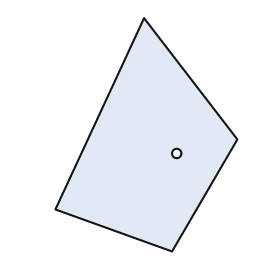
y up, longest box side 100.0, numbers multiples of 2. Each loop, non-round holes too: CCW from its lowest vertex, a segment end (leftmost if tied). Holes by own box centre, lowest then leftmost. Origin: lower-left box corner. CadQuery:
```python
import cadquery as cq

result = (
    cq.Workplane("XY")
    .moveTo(50.0, 0.0)
    .lineTo(78.0, 48.0)
    .lineTo(38.0, 100.0)
    .lineTo(0.0, 18.0)
    .close()
    .moveTo(52.0, 42.0)
    .circle(2.0)
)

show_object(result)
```